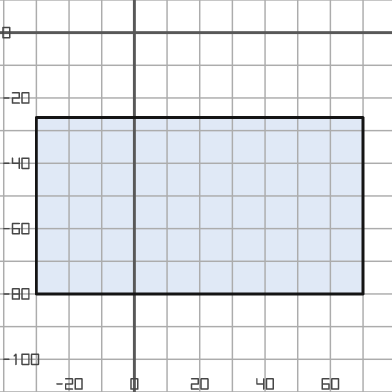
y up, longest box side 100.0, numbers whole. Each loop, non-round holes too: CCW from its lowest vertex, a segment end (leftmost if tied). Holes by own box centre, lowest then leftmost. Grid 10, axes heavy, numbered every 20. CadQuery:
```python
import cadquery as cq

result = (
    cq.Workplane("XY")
    .moveTo(-30.0, -80.0)
    .lineTo(70.0, -80.0)
    .lineTo(70.0, -26.0)
    .lineTo(-30.0, -26.0)
    .close()
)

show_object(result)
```